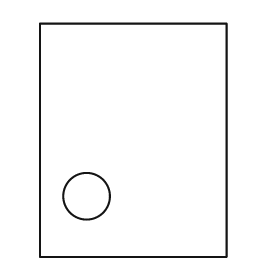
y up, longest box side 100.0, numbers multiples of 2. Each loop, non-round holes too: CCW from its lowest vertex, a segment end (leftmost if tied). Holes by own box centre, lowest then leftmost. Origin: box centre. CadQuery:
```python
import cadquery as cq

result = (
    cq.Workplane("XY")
    .moveTo(-40.0, -50.0)
    .lineTo(40.0, -50.0)
    .lineTo(40.0, 50.0)
    .lineTo(-40.0, 50.0)
    .close()
    .moveTo(-20.0, -24.0)
    .circle(10.0)
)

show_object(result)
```